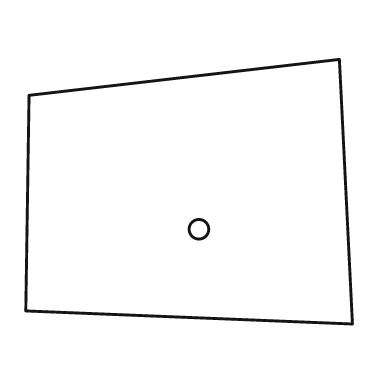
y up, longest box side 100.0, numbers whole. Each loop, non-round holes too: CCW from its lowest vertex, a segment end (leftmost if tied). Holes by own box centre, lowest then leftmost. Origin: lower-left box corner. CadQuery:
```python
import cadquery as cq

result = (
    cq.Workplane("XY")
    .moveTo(100.0, 0.0)
    .lineTo(96.0, 81.0)
    .lineTo(1.0, 70.0)
    .lineTo(0.0, 4.0)
    .close()
    .moveTo(53.0, 29.0)
    .circle(3.0)
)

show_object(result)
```